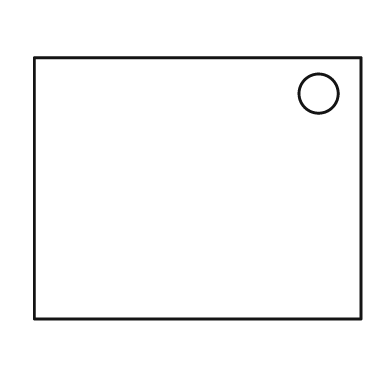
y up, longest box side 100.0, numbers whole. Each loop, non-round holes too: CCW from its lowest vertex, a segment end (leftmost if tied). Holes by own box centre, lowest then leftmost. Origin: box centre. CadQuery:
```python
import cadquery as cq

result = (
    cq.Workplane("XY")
    .moveTo(-50.0, -40.0)
    .lineTo(50.0, -40.0)
    .lineTo(50.0, 40.0)
    .lineTo(-50.0, 40.0)
    .close()
    .moveTo(37.0, 29.0)
    .circle(6.0)
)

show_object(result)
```